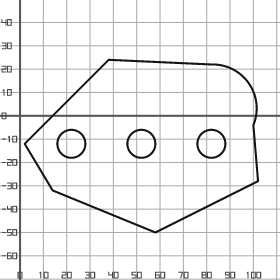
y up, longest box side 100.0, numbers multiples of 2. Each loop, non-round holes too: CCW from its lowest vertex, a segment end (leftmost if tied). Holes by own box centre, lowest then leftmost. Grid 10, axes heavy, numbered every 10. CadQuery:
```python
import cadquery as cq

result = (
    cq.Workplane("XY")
    .moveTo(58.0, -50.0)
    .lineTo(102.0, -28.0)
    .lineTo(100.0, -4.0)
    .threePointArc((98.0, 14.0), (82.0, 22.0))
    .lineTo(38.0, 24.0)
    .lineTo(2.0, -12.0)
    .lineTo(14.0, -32.0)
    .close()
    .moveTo(22.0, -12.0)
    .circle(6.0)
    .moveTo(52.0, -12.0)
    .circle(6.0)
    .moveTo(82.0, -12.0)
    .circle(6.0)
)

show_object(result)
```